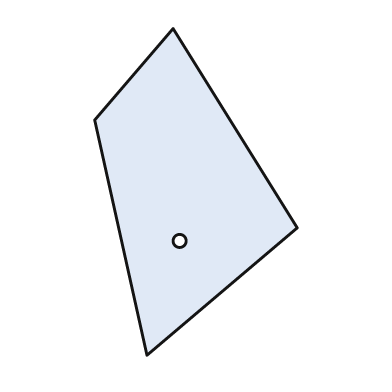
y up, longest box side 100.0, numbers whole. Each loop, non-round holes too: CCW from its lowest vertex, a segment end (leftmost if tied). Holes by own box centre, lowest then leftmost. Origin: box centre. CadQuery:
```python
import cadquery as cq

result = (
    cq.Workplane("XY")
    .moveTo(-15.0, -50.0)
    .lineTo(31.0, -11.0)
    .lineTo(-7.0, 50.0)
    .lineTo(-31.0, 22.0)
    .close()
    .moveTo(-5.0, -15.0)
    .circle(2.0)
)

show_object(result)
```